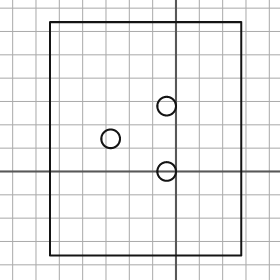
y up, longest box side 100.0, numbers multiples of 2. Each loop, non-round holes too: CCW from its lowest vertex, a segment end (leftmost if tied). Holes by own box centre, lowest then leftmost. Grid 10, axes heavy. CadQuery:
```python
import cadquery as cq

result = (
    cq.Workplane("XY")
    .moveTo(-54.0, -36.0)
    .lineTo(28.0, -36.0)
    .lineTo(28.0, 64.0)
    .lineTo(-54.0, 64.0)
    .close()
    .moveTo(-4.0, 0.0)
    .circle(4.0)
    .moveTo(-28.0, 14.0)
    .circle(4.0)
    .moveTo(-4.0, 28.0)
    .circle(4.0)
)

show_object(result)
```